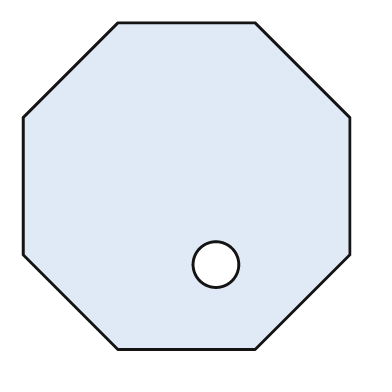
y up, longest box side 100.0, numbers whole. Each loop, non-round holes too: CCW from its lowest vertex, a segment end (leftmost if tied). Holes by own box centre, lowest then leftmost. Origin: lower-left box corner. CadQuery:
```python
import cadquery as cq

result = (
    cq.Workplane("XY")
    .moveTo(29.0, 0.0)
    .lineTo(71.0, 0.0)
    .lineTo(100.0, 29.0)
    .lineTo(100.0, 71.0)
    .lineTo(71.0, 100.0)
    .lineTo(29.0, 100.0)
    .lineTo(0.0, 71.0)
    .lineTo(0.0, 29.0)
    .close()
    .moveTo(59.0, 26.0)
    .circle(7.0)
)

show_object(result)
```